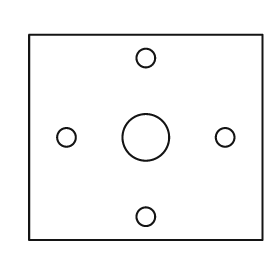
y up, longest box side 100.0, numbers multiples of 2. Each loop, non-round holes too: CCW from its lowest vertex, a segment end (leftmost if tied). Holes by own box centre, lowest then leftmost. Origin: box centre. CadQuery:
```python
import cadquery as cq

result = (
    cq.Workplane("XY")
    .moveTo(-50.0, -44.0)
    .lineTo(50.0, -44.0)
    .lineTo(50.0, 44.0)
    .lineTo(-50.0, 44.0)
    .close()
    .moveTo(0.0, -34.0)
    .circle(4.0)
    .moveTo(-34.0, 0.0)
    .circle(4.0)
    .moveTo(0.0, 0.0)
    .circle(10.0)
    .moveTo(34.0, 0.0)
    .circle(4.0)
    .moveTo(0.0, 34.0)
    .circle(4.0)
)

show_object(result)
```